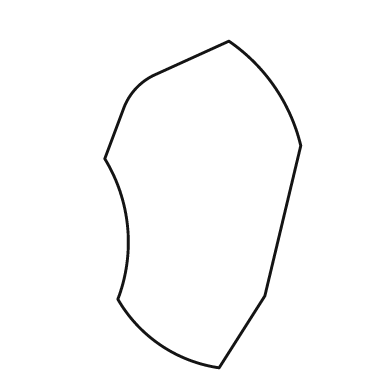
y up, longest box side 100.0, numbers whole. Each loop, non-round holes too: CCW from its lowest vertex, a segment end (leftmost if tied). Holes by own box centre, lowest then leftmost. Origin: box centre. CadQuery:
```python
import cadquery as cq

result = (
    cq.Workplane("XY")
    .moveTo(5.0, -50.0)
    .lineTo(19.0, -28.0)
    .lineTo(30.0, 18.0)
    .threePointArc((22.0, 36.0), (8.0, 50.0))
    .lineTo(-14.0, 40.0)
    .threePointArc((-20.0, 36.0), (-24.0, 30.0))
    .lineTo(-30.0, 14.0)
    .threePointArc((-23.0, -7.0), (-26.0, -29.0))
    .threePointArc((-13.0, -43.0), (5.0, -50.0))
    .close()
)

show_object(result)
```